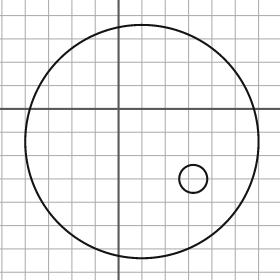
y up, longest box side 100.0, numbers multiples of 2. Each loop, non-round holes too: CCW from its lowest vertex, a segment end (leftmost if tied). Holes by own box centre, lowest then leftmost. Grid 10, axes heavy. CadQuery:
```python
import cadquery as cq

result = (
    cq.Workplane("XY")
    .moveTo(10.0, -14.0)
    .circle(50.0)
    .moveTo(32.0, -30.0)
    .circle(6.0)
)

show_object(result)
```